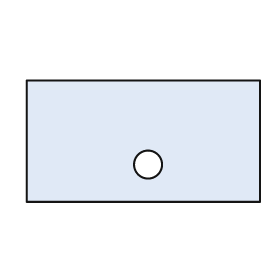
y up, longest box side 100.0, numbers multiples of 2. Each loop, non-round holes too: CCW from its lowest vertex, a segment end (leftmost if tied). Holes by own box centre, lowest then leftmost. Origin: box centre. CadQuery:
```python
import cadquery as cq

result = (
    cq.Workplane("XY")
    .moveTo(-50.0, -26.0)
    .lineTo(50.0, -26.0)
    .lineTo(50.0, 26.0)
    .lineTo(-50.0, 26.0)
    .close()
    .moveTo(2.0, -10.0)
    .circle(6.0)
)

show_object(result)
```